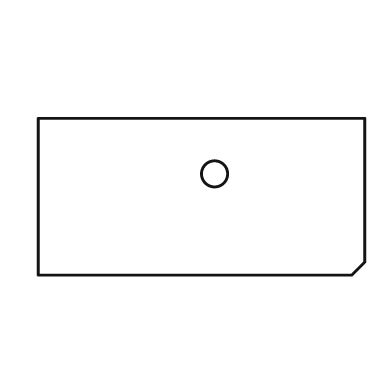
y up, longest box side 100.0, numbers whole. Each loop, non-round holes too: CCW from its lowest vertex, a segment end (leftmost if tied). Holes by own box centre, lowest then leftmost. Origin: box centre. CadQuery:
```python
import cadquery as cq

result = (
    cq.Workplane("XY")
    .moveTo(-50.0, -24.0)
    .lineTo(46.0, -24.0)
    .lineTo(50.0, -20.0)
    .lineTo(50.0, 24.0)
    .lineTo(-50.0, 24.0)
    .close()
    .moveTo(4.0, 7.0)
    .circle(4.0)
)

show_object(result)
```